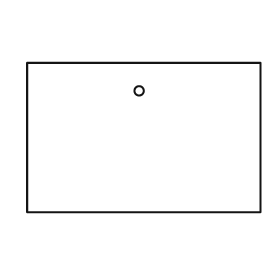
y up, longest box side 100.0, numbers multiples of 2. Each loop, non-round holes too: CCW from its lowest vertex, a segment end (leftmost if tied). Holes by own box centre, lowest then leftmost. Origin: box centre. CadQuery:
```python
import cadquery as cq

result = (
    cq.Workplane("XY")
    .moveTo(-50.0, -32.0)
    .lineTo(50.0, -32.0)
    .lineTo(50.0, 32.0)
    .lineTo(-50.0, 32.0)
    .close()
    .moveTo(-2.0, 20.0)
    .circle(2.0)
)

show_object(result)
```